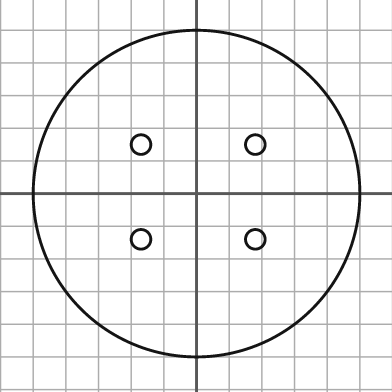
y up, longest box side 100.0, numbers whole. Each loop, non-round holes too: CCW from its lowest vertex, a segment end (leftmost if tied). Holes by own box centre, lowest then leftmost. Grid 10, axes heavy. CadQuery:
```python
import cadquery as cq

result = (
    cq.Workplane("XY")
    .moveTo(0.0, 0.0)
    .circle(50.0)
    .moveTo(-17.0, -14.0)
    .circle(3.0)
    .moveTo(18.0, -14.0)
    .circle(3.0)
    .moveTo(-17.0, 15.0)
    .circle(3.0)
    .moveTo(18.0, 15.0)
    .circle(3.0)
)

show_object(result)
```